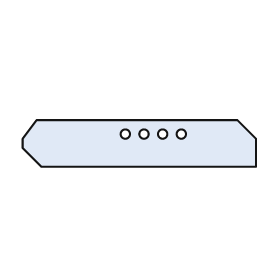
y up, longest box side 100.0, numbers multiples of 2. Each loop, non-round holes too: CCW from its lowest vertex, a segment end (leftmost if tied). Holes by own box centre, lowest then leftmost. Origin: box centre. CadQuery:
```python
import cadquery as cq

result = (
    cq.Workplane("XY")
    .moveTo(-42.0, -10.0)
    .lineTo(50.0, -10.0)
    .lineTo(50.0, 2.0)
    .lineTo(42.0, 10.0)
    .lineTo(-44.0, 10.0)
    .lineTo(-50.0, 2.0)
    .lineTo(-50.0, -2.0)
    .close()
    .moveTo(-6.0, 4.0)
    .circle(2.0)
    .moveTo(2.0, 4.0)
    .circle(2.0)
    .moveTo(10.0, 4.0)
    .circle(2.0)
    .moveTo(18.0, 4.0)
    .circle(2.0)
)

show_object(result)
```